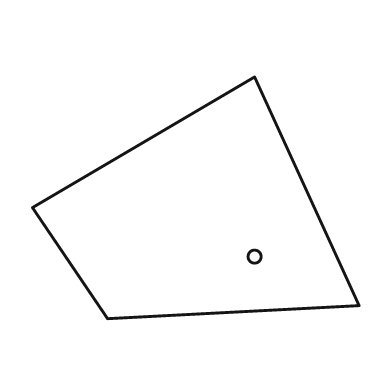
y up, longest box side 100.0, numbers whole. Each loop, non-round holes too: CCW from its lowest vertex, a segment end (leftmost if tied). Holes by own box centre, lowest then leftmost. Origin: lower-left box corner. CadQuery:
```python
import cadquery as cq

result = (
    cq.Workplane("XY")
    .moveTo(23.0, 0.0)
    .lineTo(100.0, 4.0)
    .lineTo(68.0, 74.0)
    .lineTo(0.0, 34.0)
    .close()
    .moveTo(68.0, 19.0)
    .circle(2.0)
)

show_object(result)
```